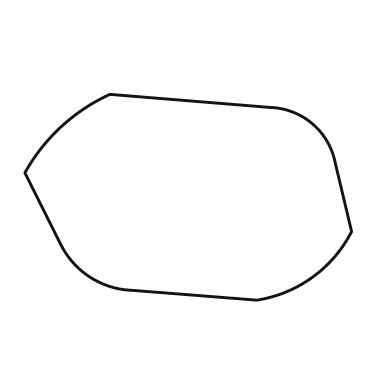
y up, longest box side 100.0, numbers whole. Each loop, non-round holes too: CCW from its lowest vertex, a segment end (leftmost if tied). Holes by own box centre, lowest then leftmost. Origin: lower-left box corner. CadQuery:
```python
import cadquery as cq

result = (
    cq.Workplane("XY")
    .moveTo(71.0, 0.0)
    .threePointArc((88.0, 7.0), (100.0, 21.0))
    .lineTo(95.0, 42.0)
    .threePointArc((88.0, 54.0), (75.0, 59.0))
    .lineTo(26.0, 63.0)
    .threePointArc((11.0, 53.0), (0.0, 39.0))
    .lineTo(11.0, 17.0)
    .threePointArc((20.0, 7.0), (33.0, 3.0))
    .close()
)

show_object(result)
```